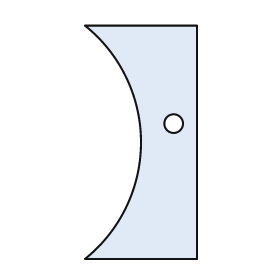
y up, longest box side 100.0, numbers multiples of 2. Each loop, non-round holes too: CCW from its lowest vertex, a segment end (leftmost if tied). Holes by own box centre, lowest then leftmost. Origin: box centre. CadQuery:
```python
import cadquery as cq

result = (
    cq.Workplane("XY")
    .moveTo(-24.0, -50.0)
    .lineTo(24.0, -50.0)
    .lineTo(24.0, 50.0)
    .lineTo(-24.0, 50.0)
    .threePointArc((0.0, 0.0), (-24.0, -50.0))
    .close()
    .moveTo(14.0, 8.0)
    .circle(4.0)
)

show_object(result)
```